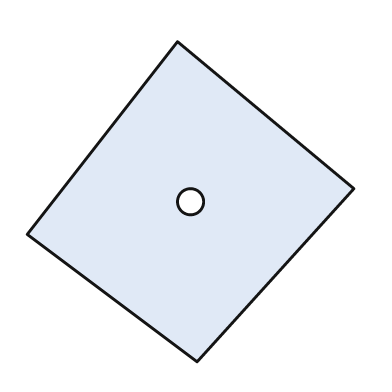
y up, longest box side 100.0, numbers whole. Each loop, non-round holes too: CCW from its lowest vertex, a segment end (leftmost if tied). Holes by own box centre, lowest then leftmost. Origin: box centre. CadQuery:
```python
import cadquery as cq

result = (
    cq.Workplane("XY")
    .moveTo(2.0, -49.0)
    .lineTo(50.0, 4.0)
    .lineTo(-4.0, 49.0)
    .lineTo(-50.0, -10.0)
    .close()
    .moveTo(0.0, 0.0)
    .circle(4.0)
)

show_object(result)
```